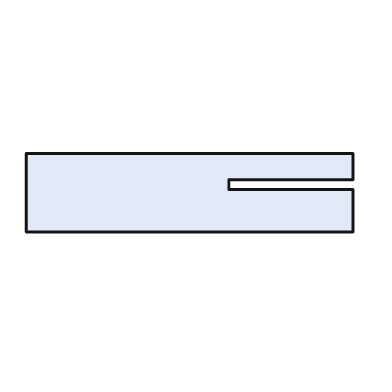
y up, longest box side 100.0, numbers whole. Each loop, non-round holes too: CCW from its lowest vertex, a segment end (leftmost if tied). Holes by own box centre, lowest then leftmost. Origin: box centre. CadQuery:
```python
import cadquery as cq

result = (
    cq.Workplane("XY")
    .moveTo(-50.0, -12.0)
    .lineTo(50.0, -12.0)
    .lineTo(50.0, 1.0)
    .lineTo(12.0, 1.0)
    .lineTo(12.0, 4.0)
    .lineTo(50.0, 4.0)
    .lineTo(50.0, 12.0)
    .lineTo(-50.0, 12.0)
    .close()
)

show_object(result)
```